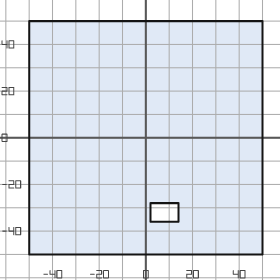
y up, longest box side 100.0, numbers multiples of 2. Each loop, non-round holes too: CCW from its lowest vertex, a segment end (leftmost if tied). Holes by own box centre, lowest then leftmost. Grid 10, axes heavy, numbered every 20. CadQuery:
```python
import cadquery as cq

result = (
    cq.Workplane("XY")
    .moveTo(-50.0, -50.0)
    .lineTo(50.0, -50.0)
    .lineTo(50.0, 50.0)
    .lineTo(-50.0, 50.0)
    .close()
    .moveTo(2.0, -36.0)
    .lineTo(14.0, -36.0)
    .lineTo(14.0, -28.0)
    .lineTo(2.0, -28.0)
    .close()
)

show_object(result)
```